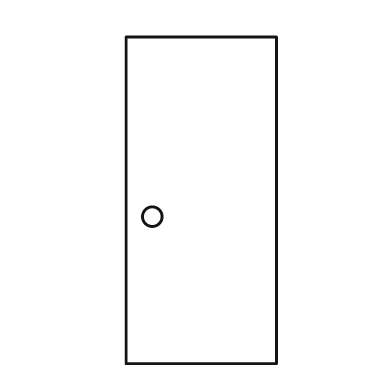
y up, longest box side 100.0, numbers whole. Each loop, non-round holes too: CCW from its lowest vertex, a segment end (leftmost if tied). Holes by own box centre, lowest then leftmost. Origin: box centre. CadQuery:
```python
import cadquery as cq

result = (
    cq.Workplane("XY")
    .moveTo(-23.0, -50.0)
    .lineTo(23.0, -50.0)
    .lineTo(23.0, 50.0)
    .lineTo(-23.0, 50.0)
    .close()
    .moveTo(-15.0, -5.0)
    .circle(3.0)
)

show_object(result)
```